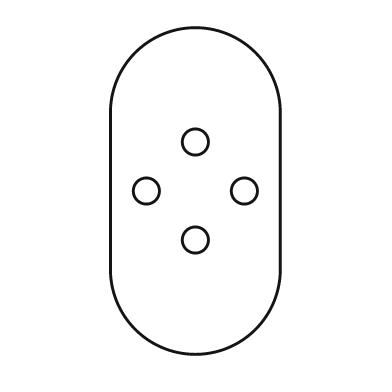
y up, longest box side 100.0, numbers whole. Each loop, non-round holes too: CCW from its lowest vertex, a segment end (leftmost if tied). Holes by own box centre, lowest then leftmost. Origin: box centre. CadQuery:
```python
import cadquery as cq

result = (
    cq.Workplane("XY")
    .moveTo(-26.0, -24.0)
    .threePointArc((0.0, -50.0), (26.0, -24.0))
    .lineTo(26.0, 24.0)
    .threePointArc((0.0, 50.0), (-26.0, 24.0))
    .close()
    .moveTo(0.0, -15.0)
    .circle(4.0)
    .moveTo(-15.0, 0.0)
    .circle(4.0)
    .moveTo(15.0, 0.0)
    .circle(4.0)
    .moveTo(0.0, 15.0)
    .circle(4.0)
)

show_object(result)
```